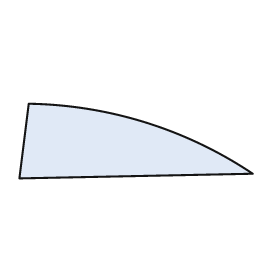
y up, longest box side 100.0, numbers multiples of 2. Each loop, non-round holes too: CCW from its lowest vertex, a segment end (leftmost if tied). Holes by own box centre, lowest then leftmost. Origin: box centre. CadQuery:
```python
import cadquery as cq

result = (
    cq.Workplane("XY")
    .moveTo(-50.0, -16.0)
    .lineTo(50.0, -14.0)
    .threePointArc((4.0, 8.0), (-46.0, 16.0))
    .close()
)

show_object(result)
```